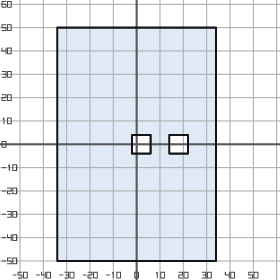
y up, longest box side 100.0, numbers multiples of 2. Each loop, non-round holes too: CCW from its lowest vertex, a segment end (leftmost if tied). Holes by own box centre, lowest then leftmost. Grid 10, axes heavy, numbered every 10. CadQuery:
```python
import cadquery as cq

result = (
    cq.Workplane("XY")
    .moveTo(-34.0, -50.0)
    .lineTo(34.0, -50.0)
    .lineTo(34.0, 50.0)
    .lineTo(-34.0, 50.0)
    .close()
    .moveTo(-2.0, -4.0)
    .lineTo(6.0, -4.0)
    .lineTo(6.0, 4.0)
    .lineTo(-2.0, 4.0)
    .close()
    .moveTo(14.0, -4.0)
    .lineTo(22.0, -4.0)
    .lineTo(22.0, 4.0)
    .lineTo(14.0, 4.0)
    .close()
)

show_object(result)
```